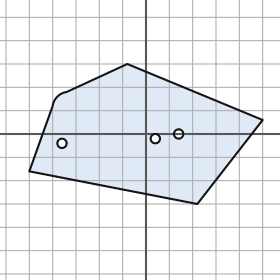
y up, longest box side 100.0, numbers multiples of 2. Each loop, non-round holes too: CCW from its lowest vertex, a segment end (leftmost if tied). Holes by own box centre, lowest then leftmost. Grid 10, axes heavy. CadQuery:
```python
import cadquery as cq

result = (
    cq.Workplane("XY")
    .moveTo(22.0, -30.0)
    .lineTo(50.0, 6.0)
    .lineTo(-8.0, 30.0)
    .lineTo(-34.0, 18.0)
    .threePointArc((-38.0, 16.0), (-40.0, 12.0))
    .lineTo(-50.0, -16.0)
    .close()
    .moveTo(-36.0, -4.0)
    .circle(2.0)
    .moveTo(4.0, -2.0)
    .circle(2.0)
    .moveTo(14.0, 0.0)
    .circle(2.0)
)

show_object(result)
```